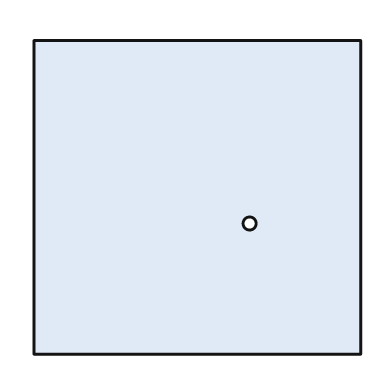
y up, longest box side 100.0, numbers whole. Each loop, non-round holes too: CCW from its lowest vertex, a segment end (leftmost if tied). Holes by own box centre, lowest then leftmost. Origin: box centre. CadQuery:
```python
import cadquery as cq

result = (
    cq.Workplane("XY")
    .moveTo(-50.0, -48.0)
    .lineTo(50.0, -48.0)
    .lineTo(50.0, 48.0)
    .lineTo(-50.0, 48.0)
    .close()
    .moveTo(16.0, -8.0)
    .circle(2.0)
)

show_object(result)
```